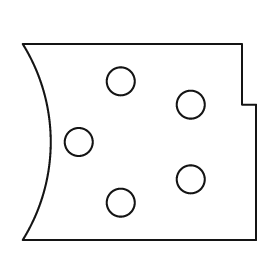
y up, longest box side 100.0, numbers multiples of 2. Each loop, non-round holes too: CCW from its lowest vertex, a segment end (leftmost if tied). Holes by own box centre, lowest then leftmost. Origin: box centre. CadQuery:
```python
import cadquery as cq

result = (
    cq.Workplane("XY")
    .moveTo(-50.0, -42.0)
    .lineTo(50.0, -42.0)
    .lineTo(50.0, 16.0)
    .lineTo(44.0, 16.0)
    .lineTo(44.0, 42.0)
    .lineTo(-50.0, 42.0)
    .threePointArc((-38.0, 0.0), (-50.0, -42.0))
    .close()
    .moveTo(-8.0, -26.0)
    .circle(6.0)
    .moveTo(22.0, -16.0)
    .circle(6.0)
    .moveTo(-26.0, 0.0)
    .circle(6.0)
    .moveTo(22.0, 16.0)
    .circle(6.0)
    .moveTo(-8.0, 26.0)
    .circle(6.0)
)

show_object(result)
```